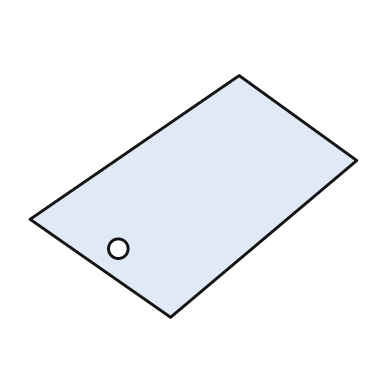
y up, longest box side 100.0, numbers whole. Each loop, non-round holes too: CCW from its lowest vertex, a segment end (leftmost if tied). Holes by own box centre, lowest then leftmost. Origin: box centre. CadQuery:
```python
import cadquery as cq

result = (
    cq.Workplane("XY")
    .moveTo(-7.0, -37.0)
    .lineTo(50.0, 11.0)
    .lineTo(14.0, 37.0)
    .lineTo(-50.0, -7.0)
    .close()
    .moveTo(-23.0, -16.0)
    .circle(3.0)
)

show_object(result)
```